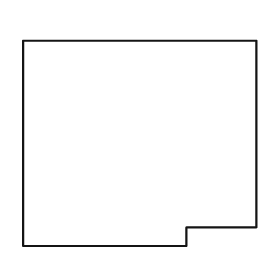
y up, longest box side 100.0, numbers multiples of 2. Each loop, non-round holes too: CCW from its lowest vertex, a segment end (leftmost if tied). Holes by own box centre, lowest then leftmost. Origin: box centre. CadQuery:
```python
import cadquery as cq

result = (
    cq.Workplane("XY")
    .moveTo(-50.0, -44.0)
    .lineTo(20.0, -44.0)
    .lineTo(20.0, -36.0)
    .lineTo(50.0, -36.0)
    .lineTo(50.0, 44.0)
    .lineTo(-50.0, 44.0)
    .close()
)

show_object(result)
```